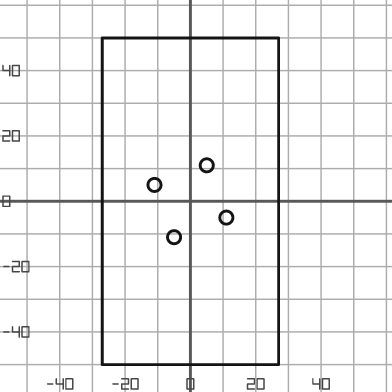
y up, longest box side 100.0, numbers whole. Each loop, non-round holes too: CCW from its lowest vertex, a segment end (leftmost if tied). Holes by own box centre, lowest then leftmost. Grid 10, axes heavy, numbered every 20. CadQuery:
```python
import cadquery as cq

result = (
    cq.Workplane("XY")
    .moveTo(-27.0, -50.0)
    .lineTo(27.0, -50.0)
    .lineTo(27.0, 50.0)
    .lineTo(-27.0, 50.0)
    .close()
    .moveTo(-5.0, -11.0)
    .circle(2.0)
    .moveTo(11.0, -5.0)
    .circle(2.0)
    .moveTo(-11.0, 5.0)
    .circle(2.0)
    .moveTo(5.0, 11.0)
    .circle(2.0)
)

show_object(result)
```